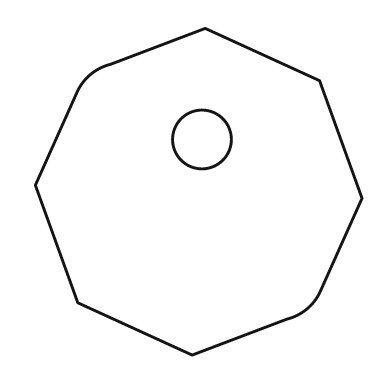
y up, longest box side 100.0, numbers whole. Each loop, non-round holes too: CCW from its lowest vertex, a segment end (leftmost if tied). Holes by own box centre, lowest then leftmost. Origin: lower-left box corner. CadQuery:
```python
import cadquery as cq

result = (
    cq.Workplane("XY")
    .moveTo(48.0, 0.0)
    .lineTo(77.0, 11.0)
    .threePointArc((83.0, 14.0), (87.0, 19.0))
    .lineTo(100.0, 48.0)
    .lineTo(87.0, 84.0)
    .lineTo(52.0, 100.0)
    .lineTo(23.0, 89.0)
    .threePointArc((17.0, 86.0), (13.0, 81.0))
    .lineTo(0.0, 52.0)
    .lineTo(13.0, 16.0)
    .close()
    .moveTo(51.0, 66.0)
    .circle(9.0)
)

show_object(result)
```